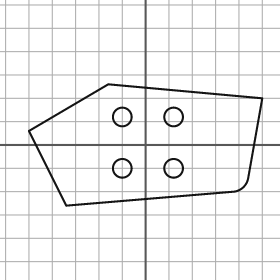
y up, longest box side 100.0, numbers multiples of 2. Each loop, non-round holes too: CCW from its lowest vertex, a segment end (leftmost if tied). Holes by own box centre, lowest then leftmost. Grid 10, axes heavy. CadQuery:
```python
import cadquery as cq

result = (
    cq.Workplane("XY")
    .moveTo(-34.0, -26.0)
    .lineTo(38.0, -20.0)
    .threePointArc((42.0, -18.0), (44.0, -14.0))
    .lineTo(50.0, 20.0)
    .lineTo(-16.0, 26.0)
    .lineTo(-50.0, 6.0)
    .close()
    .moveTo(-10.0, -10.0)
    .circle(4.0)
    .moveTo(12.0, -10.0)
    .circle(4.0)
    .moveTo(-10.0, 12.0)
    .circle(4.0)
    .moveTo(12.0, 12.0)
    .circle(4.0)
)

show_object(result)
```